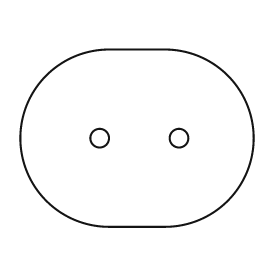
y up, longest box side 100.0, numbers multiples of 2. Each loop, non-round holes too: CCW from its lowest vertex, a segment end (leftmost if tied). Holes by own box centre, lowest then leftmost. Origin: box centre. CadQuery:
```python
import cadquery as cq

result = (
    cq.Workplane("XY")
    .moveTo(-12.0, -38.0)
    .lineTo(12.0, -38.0)
    .threePointArc((50.0, 0.0), (12.0, 38.0))
    .lineTo(-12.0, 38.0)
    .threePointArc((-50.0, 0.0), (-12.0, -38.0))
    .close()
    .moveTo(-16.0, 0.0)
    .circle(4.0)
    .moveTo(18.0, 0.0)
    .circle(4.0)
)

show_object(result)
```